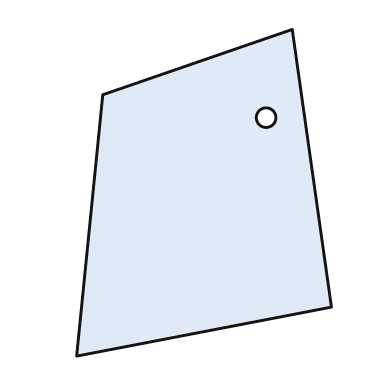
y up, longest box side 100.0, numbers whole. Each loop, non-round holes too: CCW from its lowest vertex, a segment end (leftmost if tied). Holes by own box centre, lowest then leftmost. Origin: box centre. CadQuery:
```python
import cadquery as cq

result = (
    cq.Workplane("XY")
    .moveTo(-39.0, -50.0)
    .lineTo(39.0, -35.0)
    .lineTo(27.0, 50.0)
    .lineTo(-31.0, 30.0)
    .close()
    .moveTo(19.0, 23.0)
    .circle(3.0)
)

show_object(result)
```